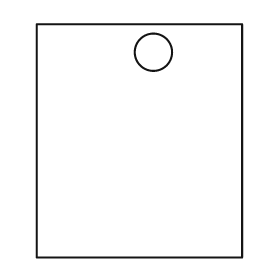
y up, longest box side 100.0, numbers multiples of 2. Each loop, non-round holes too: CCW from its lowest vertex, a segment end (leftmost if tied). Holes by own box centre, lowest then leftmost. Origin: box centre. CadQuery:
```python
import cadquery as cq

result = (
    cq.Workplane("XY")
    .moveTo(-44.0, -50.0)
    .lineTo(44.0, -50.0)
    .lineTo(44.0, 50.0)
    .lineTo(-44.0, 50.0)
    .close()
    .moveTo(6.0, 38.0)
    .circle(8.0)
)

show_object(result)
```